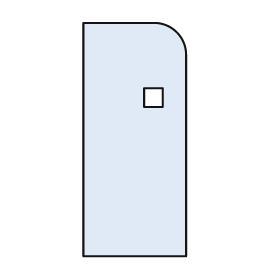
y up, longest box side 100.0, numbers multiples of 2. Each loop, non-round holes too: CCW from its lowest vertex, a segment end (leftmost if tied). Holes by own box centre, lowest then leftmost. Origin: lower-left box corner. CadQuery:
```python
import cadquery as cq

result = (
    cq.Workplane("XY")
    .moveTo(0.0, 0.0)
    .lineTo(44.0, 0.0)
    .lineTo(44.0, 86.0)
    .threePointArc((40.0, 96.0), (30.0, 100.0))
    .lineTo(0.0, 100.0)
    .close()
    .moveTo(26.0, 64.0)
    .lineTo(34.0, 64.0)
    .lineTo(34.0, 72.0)
    .lineTo(26.0, 72.0)
    .close()
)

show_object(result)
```